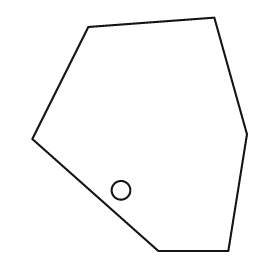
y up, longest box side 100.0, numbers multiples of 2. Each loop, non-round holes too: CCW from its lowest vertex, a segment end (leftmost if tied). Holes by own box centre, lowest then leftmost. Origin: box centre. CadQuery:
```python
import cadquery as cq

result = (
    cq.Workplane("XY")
    .moveTo(8.0, -50.0)
    .lineTo(38.0, -50.0)
    .lineTo(46.0, 0.0)
    .lineTo(32.0, 50.0)
    .lineTo(-22.0, 46.0)
    .lineTo(-46.0, -2.0)
    .close()
    .moveTo(-8.0, -24.0)
    .circle(4.0)
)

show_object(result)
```